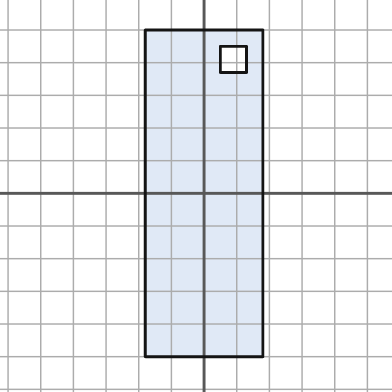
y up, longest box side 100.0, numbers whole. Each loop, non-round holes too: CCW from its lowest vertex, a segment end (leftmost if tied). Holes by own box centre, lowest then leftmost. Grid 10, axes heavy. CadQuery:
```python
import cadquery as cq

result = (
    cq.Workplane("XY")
    .moveTo(-18.0, -50.0)
    .lineTo(18.0, -50.0)
    .lineTo(18.0, 50.0)
    .lineTo(-18.0, 50.0)
    .close()
    .moveTo(5.0, 37.0)
    .lineTo(13.0, 37.0)
    .lineTo(13.0, 45.0)
    .lineTo(5.0, 45.0)
    .close()
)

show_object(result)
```